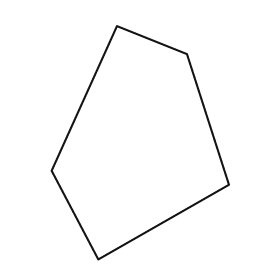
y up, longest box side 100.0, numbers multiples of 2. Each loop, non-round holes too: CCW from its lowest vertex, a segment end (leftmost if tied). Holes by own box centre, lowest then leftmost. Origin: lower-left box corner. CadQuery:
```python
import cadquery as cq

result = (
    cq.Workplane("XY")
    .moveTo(20.0, 0.0)
    .lineTo(76.0, 32.0)
    .lineTo(58.0, 88.0)
    .lineTo(28.0, 100.0)
    .lineTo(0.0, 38.0)
    .close()
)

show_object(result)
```